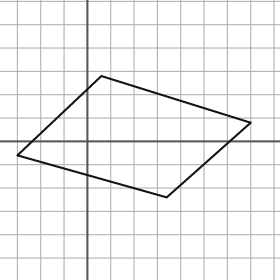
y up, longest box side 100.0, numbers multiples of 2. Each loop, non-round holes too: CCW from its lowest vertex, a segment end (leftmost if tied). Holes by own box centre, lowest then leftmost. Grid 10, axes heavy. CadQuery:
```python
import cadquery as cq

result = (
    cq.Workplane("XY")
    .moveTo(34.0, -24.0)
    .lineTo(70.0, 8.0)
    .lineTo(6.0, 28.0)
    .lineTo(-30.0, -6.0)
    .close()
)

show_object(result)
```